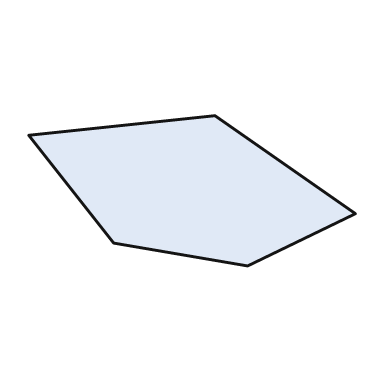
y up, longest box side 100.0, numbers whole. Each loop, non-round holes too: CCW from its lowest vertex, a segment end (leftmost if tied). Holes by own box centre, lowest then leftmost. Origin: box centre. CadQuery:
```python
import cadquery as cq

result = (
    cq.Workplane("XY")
    .moveTo(17.0, -23.0)
    .lineTo(50.0, -7.0)
    .lineTo(7.0, 23.0)
    .lineTo(-50.0, 17.0)
    .lineTo(-24.0, -16.0)
    .close()
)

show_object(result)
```